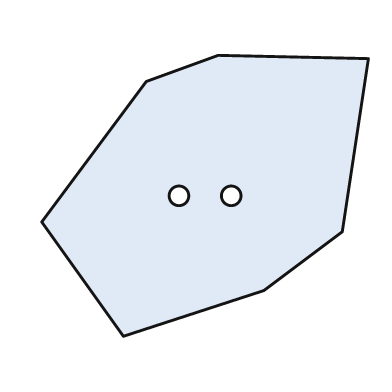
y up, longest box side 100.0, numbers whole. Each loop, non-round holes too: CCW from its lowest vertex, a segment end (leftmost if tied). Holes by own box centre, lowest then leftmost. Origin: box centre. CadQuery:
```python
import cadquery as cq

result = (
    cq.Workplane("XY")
    .moveTo(-25.0, -43.0)
    .lineTo(18.0, -29.0)
    .lineTo(42.0, -11.0)
    .lineTo(50.0, 42.0)
    .lineTo(4.0, 43.0)
    .lineTo(-18.0, 35.0)
    .lineTo(-50.0, -8.0)
    .close()
    .moveTo(-8.0, 0.0)
    .circle(3.0)
    .moveTo(8.0, 0.0)
    .circle(3.0)
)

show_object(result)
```